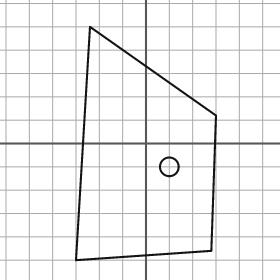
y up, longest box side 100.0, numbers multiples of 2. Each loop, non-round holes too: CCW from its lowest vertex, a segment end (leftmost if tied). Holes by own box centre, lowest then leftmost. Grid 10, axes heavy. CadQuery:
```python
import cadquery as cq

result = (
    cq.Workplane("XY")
    .moveTo(-30.0, -50.0)
    .lineTo(28.0, -46.0)
    .lineTo(30.0, 12.0)
    .lineTo(-24.0, 50.0)
    .close()
    .moveTo(10.0, -10.0)
    .circle(4.0)
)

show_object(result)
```